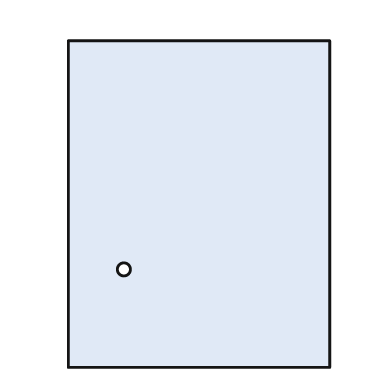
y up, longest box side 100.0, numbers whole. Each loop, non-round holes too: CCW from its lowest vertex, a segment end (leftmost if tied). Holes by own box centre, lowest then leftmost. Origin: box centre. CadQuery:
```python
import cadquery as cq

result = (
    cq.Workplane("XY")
    .moveTo(-40.0, -50.0)
    .lineTo(40.0, -50.0)
    .lineTo(40.0, 50.0)
    .lineTo(-40.0, 50.0)
    .close()
    .moveTo(-23.0, -20.0)
    .circle(2.0)
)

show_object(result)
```